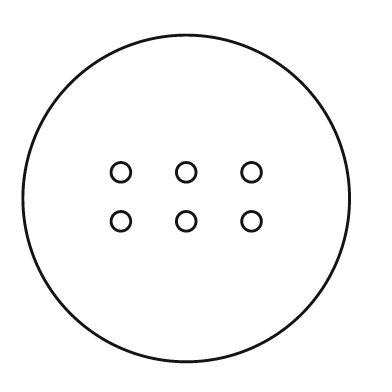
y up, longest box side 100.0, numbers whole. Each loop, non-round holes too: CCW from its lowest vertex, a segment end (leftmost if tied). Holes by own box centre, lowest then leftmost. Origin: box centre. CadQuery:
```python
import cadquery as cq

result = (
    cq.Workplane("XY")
    .moveTo(0.0, 0.0)
    .circle(50.0)
    .moveTo(-20.0, -7.0)
    .circle(3.0)
    .moveTo(0.0, -7.0)
    .circle(3.0)
    .moveTo(20.0, -7.0)
    .circle(3.0)
    .moveTo(-20.0, 8.0)
    .circle(3.0)
    .moveTo(0.0, 8.0)
    .circle(3.0)
    .moveTo(20.0, 8.0)
    .circle(3.0)
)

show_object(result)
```